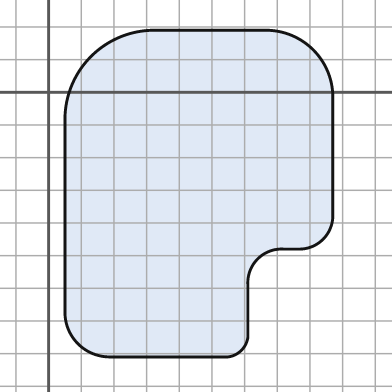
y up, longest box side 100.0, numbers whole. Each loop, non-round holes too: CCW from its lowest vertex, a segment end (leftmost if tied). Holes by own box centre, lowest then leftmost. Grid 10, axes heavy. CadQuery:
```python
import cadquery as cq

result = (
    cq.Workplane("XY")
    .moveTo(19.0, -81.0)
    .lineTo(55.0, -81.0)
    .threePointArc((59.0, -79.0), (61.0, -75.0))
    .lineTo(61.0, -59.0)
    .threePointArc((64.0, -51.0), (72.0, -48.0))
    .lineTo(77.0, -48.0)
    .threePointArc((84.0, -45.0), (87.0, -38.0))
    .lineTo(87.0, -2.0)
    .threePointArc((81.0, 13.0), (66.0, 19.0))
    .lineTo(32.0, 19.0)
    .threePointArc((13.0, 11.0), (5.0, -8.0))
    .lineTo(5.0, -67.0)
    .threePointArc((9.0, -77.0), (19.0, -81.0))
    .close()
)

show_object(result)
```